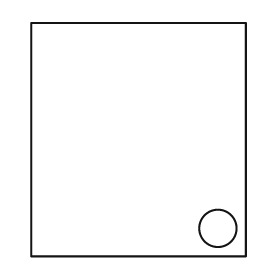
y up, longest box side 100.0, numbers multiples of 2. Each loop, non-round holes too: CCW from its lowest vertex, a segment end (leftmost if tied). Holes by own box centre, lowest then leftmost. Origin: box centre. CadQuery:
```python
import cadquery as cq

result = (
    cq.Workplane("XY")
    .moveTo(-46.0, -50.0)
    .lineTo(46.0, -50.0)
    .lineTo(46.0, 50.0)
    .lineTo(-46.0, 50.0)
    .close()
    .moveTo(34.0, -38.0)
    .circle(8.0)
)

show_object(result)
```